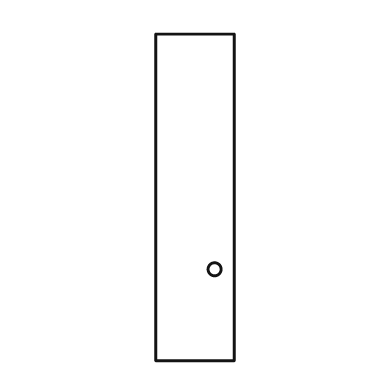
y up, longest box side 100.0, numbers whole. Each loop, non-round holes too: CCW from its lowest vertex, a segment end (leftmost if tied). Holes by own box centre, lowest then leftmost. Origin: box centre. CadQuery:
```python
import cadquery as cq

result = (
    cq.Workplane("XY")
    .moveTo(-12.0, -50.0)
    .lineTo(12.0, -50.0)
    .lineTo(12.0, 50.0)
    .lineTo(-12.0, 50.0)
    .close()
    .moveTo(6.0, -22.0)
    .circle(2.0)
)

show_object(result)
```